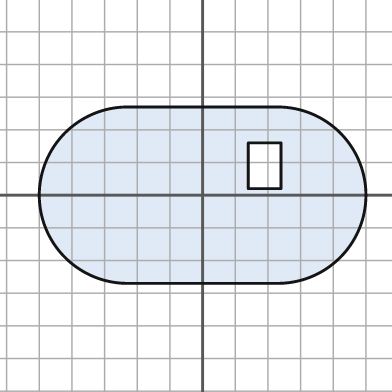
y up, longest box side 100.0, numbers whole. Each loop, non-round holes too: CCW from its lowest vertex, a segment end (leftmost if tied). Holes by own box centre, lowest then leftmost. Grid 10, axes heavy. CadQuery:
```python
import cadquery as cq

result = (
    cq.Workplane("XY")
    .moveTo(-23.0, -27.0)
    .lineTo(23.0, -27.0)
    .threePointArc((50.0, 0.0), (23.0, 27.0))
    .lineTo(-23.0, 27.0)
    .threePointArc((-50.0, 0.0), (-23.0, -27.0))
    .close()
    .moveTo(14.0, 2.0)
    .lineTo(24.0, 2.0)
    .lineTo(24.0, 16.0)
    .lineTo(14.0, 16.0)
    .close()
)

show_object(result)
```